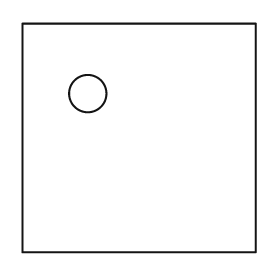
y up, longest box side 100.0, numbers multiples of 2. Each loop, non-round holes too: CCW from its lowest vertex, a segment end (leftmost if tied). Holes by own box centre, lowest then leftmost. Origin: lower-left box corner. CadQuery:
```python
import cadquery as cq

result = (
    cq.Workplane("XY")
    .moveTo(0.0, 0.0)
    .lineTo(100.0, 0.0)
    .lineTo(100.0, 98.0)
    .lineTo(0.0, 98.0)
    .close()
    .moveTo(28.0, 68.0)
    .circle(8.0)
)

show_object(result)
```